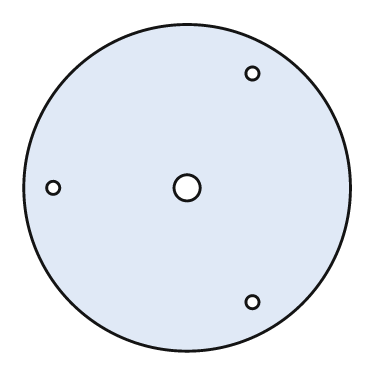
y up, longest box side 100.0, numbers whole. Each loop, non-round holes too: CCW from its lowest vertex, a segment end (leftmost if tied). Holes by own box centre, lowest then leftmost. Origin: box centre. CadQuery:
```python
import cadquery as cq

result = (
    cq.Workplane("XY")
    .moveTo(0.0, 0.0)
    .circle(50.0)
    .moveTo(20.0, -35.0)
    .circle(2.0)
    .moveTo(-41.0, 0.0)
    .circle(2.0)
    .moveTo(0.0, 0.0)
    .circle(4.0)
    .moveTo(20.0, 35.0)
    .circle(2.0)
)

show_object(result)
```